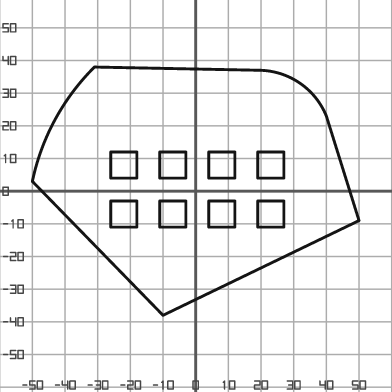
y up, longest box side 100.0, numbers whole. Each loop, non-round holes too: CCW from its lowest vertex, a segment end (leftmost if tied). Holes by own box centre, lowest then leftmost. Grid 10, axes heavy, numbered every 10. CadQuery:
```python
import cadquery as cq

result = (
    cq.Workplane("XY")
    .moveTo(-10.0, -38.0)
    .lineTo(50.0, -9.0)
    .lineTo(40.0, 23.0)
    .threePointArc((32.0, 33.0), (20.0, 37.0))
    .lineTo(-31.0, 38.0)
    .threePointArc((-43.0, 22.0), (-50.0, 3.0))
    .close()
    .moveTo(-26.0, -11.0)
    .lineTo(-18.0, -11.0)
    .lineTo(-18.0, -3.0)
    .lineTo(-26.0, -3.0)
    .close()
    .moveTo(-11.0, -11.0)
    .lineTo(-3.0, -11.0)
    .lineTo(-3.0, -3.0)
    .lineTo(-11.0, -3.0)
    .close()
    .moveTo(4.0, -11.0)
    .lineTo(12.0, -11.0)
    .lineTo(12.0, -3.0)
    .lineTo(4.0, -3.0)
    .close()
    .moveTo(19.0, -11.0)
    .lineTo(27.0, -11.0)
    .lineTo(27.0, -3.0)
    .lineTo(19.0, -3.0)
    .close()
    .moveTo(-26.0, 4.0)
    .lineTo(-18.0, 4.0)
    .lineTo(-18.0, 12.0)
    .lineTo(-26.0, 12.0)
    .close()
    .moveTo(-11.0, 4.0)
    .lineTo(-3.0, 4.0)
    .lineTo(-3.0, 12.0)
    .lineTo(-11.0, 12.0)
    .close()
    .moveTo(4.0, 4.0)
    .lineTo(12.0, 4.0)
    .lineTo(12.0, 12.0)
    .lineTo(4.0, 12.0)
    .close()
    .moveTo(19.0, 4.0)
    .lineTo(27.0, 4.0)
    .lineTo(27.0, 12.0)
    .lineTo(19.0, 12.0)
    .close()
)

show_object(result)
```